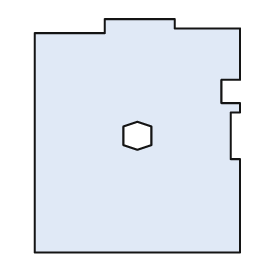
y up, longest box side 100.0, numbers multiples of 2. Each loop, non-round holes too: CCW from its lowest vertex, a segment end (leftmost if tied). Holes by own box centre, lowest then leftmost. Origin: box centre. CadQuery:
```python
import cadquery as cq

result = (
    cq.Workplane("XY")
    .moveTo(-44.0, -50.0)
    .lineTo(44.0, -50.0)
    .lineTo(44.0, -10.0)
    .lineTo(40.0, -10.0)
    .lineTo(40.0, 10.0)
    .lineTo(44.0, 10.0)
    .lineTo(44.0, 14.0)
    .lineTo(36.0, 14.0)
    .lineTo(36.0, 24.0)
    .lineTo(44.0, 24.0)
    .lineTo(44.0, 46.0)
    .lineTo(16.0, 46.0)
    .lineTo(16.0, 50.0)
    .lineTo(-14.0, 50.0)
    .lineTo(-14.0, 44.0)
    .lineTo(-44.0, 44.0)
    .close()
    .moveTo(0.0, -6.0)
    .lineTo(6.0, -4.0)
    .lineTo(6.0, 4.0)
    .lineTo(0.0, 6.0)
    .lineTo(-6.0, 4.0)
    .lineTo(-6.0, -4.0)
    .close()
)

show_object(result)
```